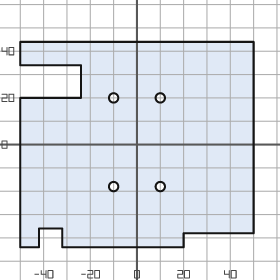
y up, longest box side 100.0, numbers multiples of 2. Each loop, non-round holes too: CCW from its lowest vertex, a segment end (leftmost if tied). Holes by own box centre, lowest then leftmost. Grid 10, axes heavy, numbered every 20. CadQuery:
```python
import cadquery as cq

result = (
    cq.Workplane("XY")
    .moveTo(-50.0, -44.0)
    .lineTo(-42.0, -44.0)
    .lineTo(-42.0, -36.0)
    .lineTo(-32.0, -36.0)
    .lineTo(-32.0, -44.0)
    .lineTo(20.0, -44.0)
    .lineTo(20.0, -38.0)
    .lineTo(50.0, -38.0)
    .lineTo(50.0, 44.0)
    .lineTo(-50.0, 44.0)
    .lineTo(-50.0, 34.0)
    .lineTo(-24.0, 34.0)
    .lineTo(-24.0, 20.0)
    .lineTo(-50.0, 20.0)
    .close()
    .moveTo(-10.0, -18.0)
    .circle(2.0)
    .moveTo(10.0, -18.0)
    .circle(2.0)
    .moveTo(-10.0, 20.0)
    .circle(2.0)
    .moveTo(10.0, 20.0)
    .circle(2.0)
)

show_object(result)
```